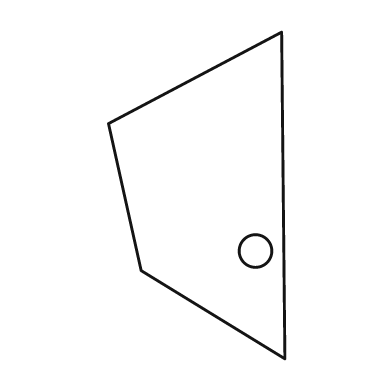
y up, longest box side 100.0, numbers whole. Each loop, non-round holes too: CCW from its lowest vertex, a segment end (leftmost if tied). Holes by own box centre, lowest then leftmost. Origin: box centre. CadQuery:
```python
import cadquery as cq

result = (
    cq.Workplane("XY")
    .moveTo(27.0, -50.0)
    .lineTo(26.0, 50.0)
    .lineTo(-27.0, 22.0)
    .lineTo(-17.0, -23.0)
    .close()
    .moveTo(18.0, -17.0)
    .circle(5.0)
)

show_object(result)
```